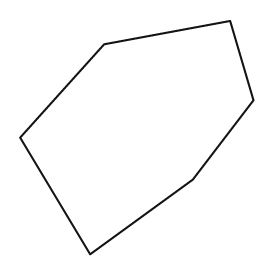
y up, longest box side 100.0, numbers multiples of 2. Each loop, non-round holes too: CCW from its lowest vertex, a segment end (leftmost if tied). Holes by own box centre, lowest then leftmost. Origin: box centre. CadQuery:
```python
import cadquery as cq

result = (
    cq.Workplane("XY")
    .moveTo(-20.0, -50.0)
    .lineTo(24.0, -18.0)
    .lineTo(50.0, 16.0)
    .lineTo(40.0, 50.0)
    .lineTo(-14.0, 40.0)
    .lineTo(-50.0, 0.0)
    .close()
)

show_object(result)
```